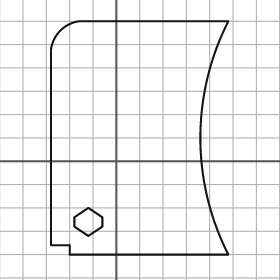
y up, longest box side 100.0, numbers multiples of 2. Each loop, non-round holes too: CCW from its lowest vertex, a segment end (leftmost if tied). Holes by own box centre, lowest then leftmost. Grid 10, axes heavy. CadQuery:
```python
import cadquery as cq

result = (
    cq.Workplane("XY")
    .moveTo(-20.0, -40.0)
    .lineTo(48.0, -40.0)
    .threePointArc((36.0, 10.0), (48.0, 60.0))
    .lineTo(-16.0, 60.0)
    .threePointArc((-24.0, 56.0), (-28.0, 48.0))
    .lineTo(-28.0, -36.0)
    .lineTo(-20.0, -36.0)
    .close()
    .moveTo(-12.0, -32.0)
    .lineTo(-6.0, -28.0)
    .lineTo(-6.0, -24.0)
    .lineTo(-12.0, -20.0)
    .lineTo(-18.0, -24.0)
    .lineTo(-18.0, -28.0)
    .close()
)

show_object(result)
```